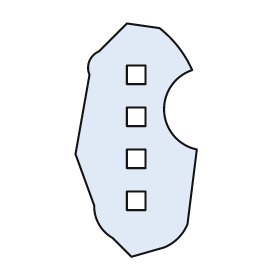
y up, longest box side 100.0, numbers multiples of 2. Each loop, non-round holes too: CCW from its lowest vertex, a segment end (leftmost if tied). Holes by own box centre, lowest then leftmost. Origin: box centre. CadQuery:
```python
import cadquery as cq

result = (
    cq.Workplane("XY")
    .moveTo(-2.0, -50.0)
    .lineTo(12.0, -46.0)
    .threePointArc((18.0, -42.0), (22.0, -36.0))
    .lineTo(26.0, -4.0)
    .threePointArc((12.0, 12.0), (24.0, 30.0))
    .threePointArc((18.0, 40.0), (10.0, 48.0))
    .lineTo(-4.0, 50.0)
    .lineTo(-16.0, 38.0)
    .threePointArc((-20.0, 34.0), (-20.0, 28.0))
    .lineTo(-26.0, -6.0)
    .lineTo(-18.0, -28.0)
    .threePointArc((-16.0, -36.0), (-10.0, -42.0))
    .close()
    .moveTo(-4.0, -30.0)
    .lineTo(4.0, -30.0)
    .lineTo(4.0, -22.0)
    .lineTo(-4.0, -22.0)
    .close()
    .moveTo(-4.0, -12.0)
    .lineTo(4.0, -12.0)
    .lineTo(4.0, -4.0)
    .lineTo(-4.0, -4.0)
    .close()
    .moveTo(-4.0, 6.0)
    .lineTo(4.0, 6.0)
    .lineTo(4.0, 14.0)
    .lineTo(-4.0, 14.0)
    .close()
    .moveTo(-4.0, 24.0)
    .lineTo(4.0, 24.0)
    .lineTo(4.0, 32.0)
    .lineTo(-4.0, 32.0)
    .close()
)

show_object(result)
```